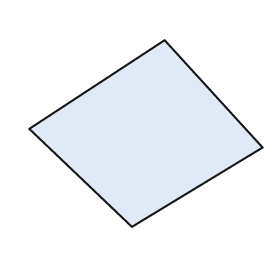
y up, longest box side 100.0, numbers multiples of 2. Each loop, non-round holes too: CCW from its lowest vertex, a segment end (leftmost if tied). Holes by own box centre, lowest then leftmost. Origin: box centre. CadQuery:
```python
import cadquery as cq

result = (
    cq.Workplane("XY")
    .moveTo(-6.0, -40.0)
    .lineTo(50.0, -6.0)
    .lineTo(8.0, 40.0)
    .lineTo(-50.0, 2.0)
    .close()
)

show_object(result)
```